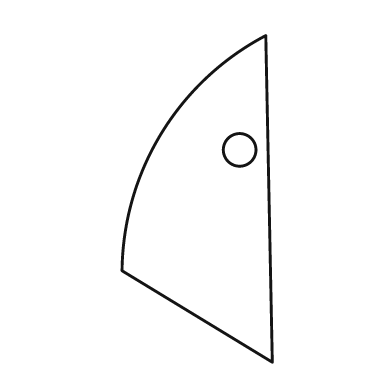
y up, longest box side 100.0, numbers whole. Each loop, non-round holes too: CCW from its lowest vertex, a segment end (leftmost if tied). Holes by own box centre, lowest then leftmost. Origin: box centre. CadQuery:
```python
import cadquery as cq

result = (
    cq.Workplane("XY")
    .moveTo(23.0, -50.0)
    .lineTo(21.0, 50.0)
    .threePointArc((-11.0, 20.0), (-23.0, -22.0))
    .close()
    .moveTo(13.0, 15.0)
    .circle(5.0)
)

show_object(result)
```